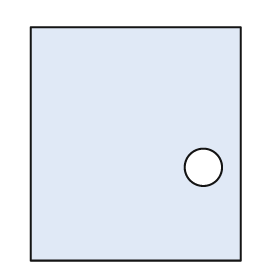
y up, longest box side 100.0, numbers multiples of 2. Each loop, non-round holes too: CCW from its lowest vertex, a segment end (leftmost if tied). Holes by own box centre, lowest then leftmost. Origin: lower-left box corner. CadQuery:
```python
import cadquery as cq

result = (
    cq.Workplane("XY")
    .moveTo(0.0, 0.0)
    .lineTo(90.0, 0.0)
    .lineTo(90.0, 100.0)
    .lineTo(0.0, 100.0)
    .close()
    .moveTo(74.0, 40.0)
    .circle(8.0)
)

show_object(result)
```